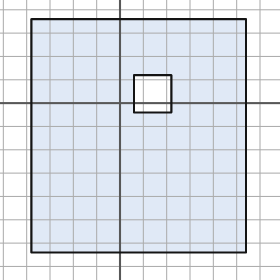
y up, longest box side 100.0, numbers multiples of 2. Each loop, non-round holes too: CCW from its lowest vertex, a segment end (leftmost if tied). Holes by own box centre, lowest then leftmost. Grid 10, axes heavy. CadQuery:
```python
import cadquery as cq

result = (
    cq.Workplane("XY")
    .moveTo(-38.0, -64.0)
    .lineTo(54.0, -64.0)
    .lineTo(54.0, 36.0)
    .lineTo(-38.0, 36.0)
    .close()
    .moveTo(6.0, -4.0)
    .lineTo(22.0, -4.0)
    .lineTo(22.0, 12.0)
    .lineTo(6.0, 12.0)
    .close()
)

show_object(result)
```